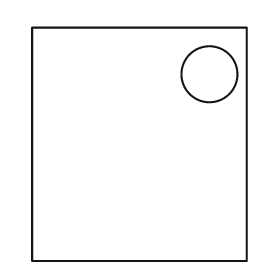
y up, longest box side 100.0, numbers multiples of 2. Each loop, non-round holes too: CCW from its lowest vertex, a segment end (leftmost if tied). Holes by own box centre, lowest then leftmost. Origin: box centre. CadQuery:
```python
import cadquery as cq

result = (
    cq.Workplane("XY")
    .moveTo(-46.0, -50.0)
    .lineTo(46.0, -50.0)
    .lineTo(46.0, 50.0)
    .lineTo(-46.0, 50.0)
    .close()
    .moveTo(30.0, 30.0)
    .circle(12.0)
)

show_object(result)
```